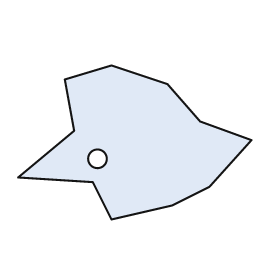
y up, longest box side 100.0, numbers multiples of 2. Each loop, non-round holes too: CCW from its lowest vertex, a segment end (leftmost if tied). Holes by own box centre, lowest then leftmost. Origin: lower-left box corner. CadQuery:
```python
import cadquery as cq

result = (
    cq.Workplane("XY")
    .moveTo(40.0, 0.0)
    .lineTo(66.0, 6.0)
    .lineTo(82.0, 14.0)
    .lineTo(100.0, 34.0)
    .lineTo(78.0, 42.0)
    .lineTo(64.0, 58.0)
    .lineTo(40.0, 66.0)
    .lineTo(20.0, 60.0)
    .lineTo(24.0, 38.0)
    .lineTo(0.0, 18.0)
    .lineTo(32.0, 16.0)
    .close()
    .moveTo(34.0, 26.0)
    .circle(4.0)
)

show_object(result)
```